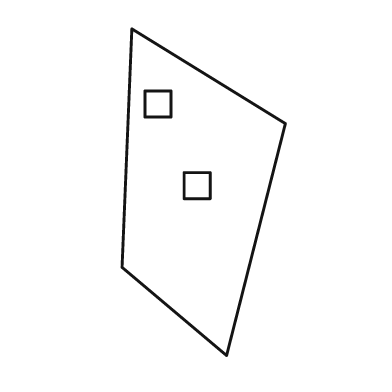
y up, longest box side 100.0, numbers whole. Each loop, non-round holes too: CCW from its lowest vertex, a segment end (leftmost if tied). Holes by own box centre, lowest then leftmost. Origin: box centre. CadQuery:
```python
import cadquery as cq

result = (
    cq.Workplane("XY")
    .moveTo(7.0, -50.0)
    .lineTo(25.0, 21.0)
    .lineTo(-22.0, 50.0)
    .lineTo(-25.0, -23.0)
    .close()
    .moveTo(-6.0, -2.0)
    .lineTo(2.0, -2.0)
    .lineTo(2.0, 6.0)
    .lineTo(-6.0, 6.0)
    .close()
    .moveTo(-18.0, 23.0)
    .lineTo(-10.0, 23.0)
    .lineTo(-10.0, 31.0)
    .lineTo(-18.0, 31.0)
    .close()
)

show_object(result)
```